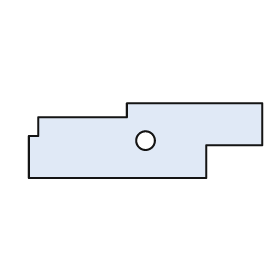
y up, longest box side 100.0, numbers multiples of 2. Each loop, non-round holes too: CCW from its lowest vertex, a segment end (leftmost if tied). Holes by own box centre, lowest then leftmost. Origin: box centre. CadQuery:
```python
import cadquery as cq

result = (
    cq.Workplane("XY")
    .moveTo(-50.0, -16.0)
    .lineTo(26.0, -16.0)
    .lineTo(26.0, -2.0)
    .lineTo(50.0, -2.0)
    .lineTo(50.0, 16.0)
    .lineTo(-8.0, 16.0)
    .lineTo(-8.0, 10.0)
    .lineTo(-46.0, 10.0)
    .lineTo(-46.0, 2.0)
    .lineTo(-50.0, 2.0)
    .close()
    .moveTo(0.0, 0.0)
    .circle(4.0)
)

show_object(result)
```